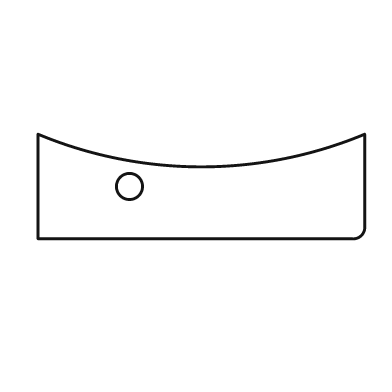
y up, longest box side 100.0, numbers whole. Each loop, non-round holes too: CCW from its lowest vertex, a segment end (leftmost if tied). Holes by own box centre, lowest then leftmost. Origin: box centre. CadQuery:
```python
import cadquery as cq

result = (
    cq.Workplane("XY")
    .moveTo(-50.0, -16.0)
    .lineTo(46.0, -16.0)
    .threePointArc((49.0, -15.0), (50.0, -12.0))
    .lineTo(50.0, 16.0)
    .threePointArc((0.0, 6.0), (-50.0, 16.0))
    .close()
    .moveTo(-22.0, 0.0)
    .circle(4.0)
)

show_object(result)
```